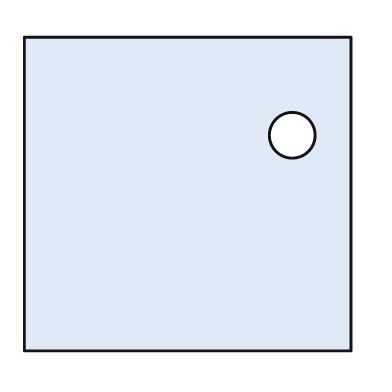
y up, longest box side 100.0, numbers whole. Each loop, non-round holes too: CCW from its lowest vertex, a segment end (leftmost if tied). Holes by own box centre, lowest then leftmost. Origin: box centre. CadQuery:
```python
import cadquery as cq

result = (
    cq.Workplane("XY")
    .moveTo(-50.0, -48.0)
    .lineTo(50.0, -48.0)
    .lineTo(50.0, 48.0)
    .lineTo(-50.0, 48.0)
    .close()
    .moveTo(32.0, 18.0)
    .circle(7.0)
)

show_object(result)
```